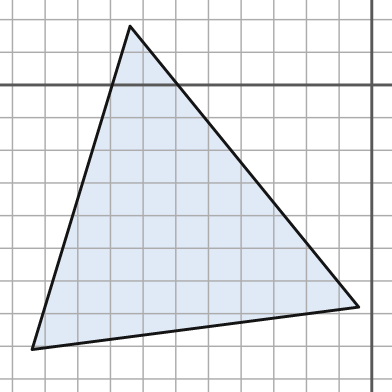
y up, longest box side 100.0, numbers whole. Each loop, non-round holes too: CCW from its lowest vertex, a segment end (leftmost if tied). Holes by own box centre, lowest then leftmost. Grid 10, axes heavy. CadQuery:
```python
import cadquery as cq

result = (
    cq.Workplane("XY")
    .moveTo(-104.0, -81.0)
    .lineTo(-4.0, -68.0)
    .lineTo(-74.0, 18.0)
    .close()
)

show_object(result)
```